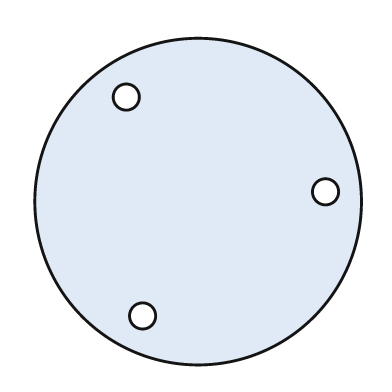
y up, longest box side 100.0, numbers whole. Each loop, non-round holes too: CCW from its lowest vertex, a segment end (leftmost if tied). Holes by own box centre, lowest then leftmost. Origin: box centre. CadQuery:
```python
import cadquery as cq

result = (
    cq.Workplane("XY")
    .moveTo(0.0, 0.0)
    .circle(50.0)
    .moveTo(-17.0, -35.0)
    .circle(4.0)
    .moveTo(39.0, 3.0)
    .circle(4.0)
    .moveTo(-22.0, 32.0)
    .circle(4.0)
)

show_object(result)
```